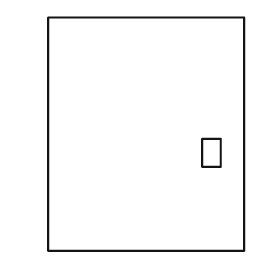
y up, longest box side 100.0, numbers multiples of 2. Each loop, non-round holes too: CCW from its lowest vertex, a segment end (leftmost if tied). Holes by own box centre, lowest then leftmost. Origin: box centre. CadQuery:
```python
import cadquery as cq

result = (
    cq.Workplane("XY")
    .moveTo(-42.0, -50.0)
    .lineTo(42.0, -50.0)
    .lineTo(42.0, 50.0)
    .lineTo(-42.0, 50.0)
    .close()
    .moveTo(24.0, -14.0)
    .lineTo(32.0, -14.0)
    .lineTo(32.0, -2.0)
    .lineTo(24.0, -2.0)
    .close()
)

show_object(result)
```